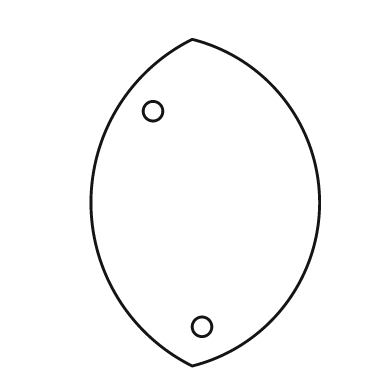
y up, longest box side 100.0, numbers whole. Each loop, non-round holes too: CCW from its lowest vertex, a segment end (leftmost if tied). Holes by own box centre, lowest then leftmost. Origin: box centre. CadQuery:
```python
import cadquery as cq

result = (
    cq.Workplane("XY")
    .moveTo(-4.0, -50.0)
    .threePointArc((35.0, 0.0), (-4.0, 50.0))
    .threePointArc((-35.0, 0.0), (-4.0, -50.0))
    .close()
    .moveTo(-1.0, -38.0)
    .circle(3.0)
    .moveTo(-16.0, 28.0)
    .circle(3.0)
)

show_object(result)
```